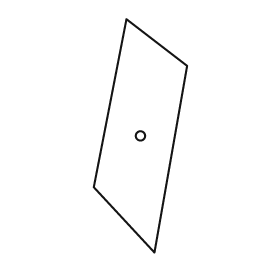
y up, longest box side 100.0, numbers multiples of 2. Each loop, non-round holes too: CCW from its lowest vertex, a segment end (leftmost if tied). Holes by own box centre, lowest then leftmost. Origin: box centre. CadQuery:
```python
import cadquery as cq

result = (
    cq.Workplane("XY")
    .moveTo(6.0, -50.0)
    .lineTo(20.0, 30.0)
    .lineTo(-6.0, 50.0)
    .lineTo(-20.0, -22.0)
    .close()
    .moveTo(0.0, 0.0)
    .circle(2.0)
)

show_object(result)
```